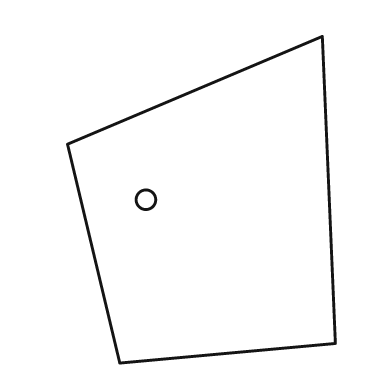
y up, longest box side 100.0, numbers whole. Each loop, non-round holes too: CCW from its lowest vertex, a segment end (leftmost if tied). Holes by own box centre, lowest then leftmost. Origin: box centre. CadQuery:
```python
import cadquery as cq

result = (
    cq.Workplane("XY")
    .moveTo(-25.0, -50.0)
    .lineTo(41.0, -44.0)
    .lineTo(37.0, 50.0)
    .lineTo(-41.0, 17.0)
    .close()
    .moveTo(-17.0, 0.0)
    .circle(3.0)
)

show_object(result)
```